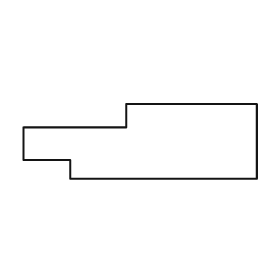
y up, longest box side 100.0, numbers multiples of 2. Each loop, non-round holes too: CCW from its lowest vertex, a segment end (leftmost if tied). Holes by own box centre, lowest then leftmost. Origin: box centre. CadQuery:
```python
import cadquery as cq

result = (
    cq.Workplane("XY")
    .moveTo(-30.0, -16.0)
    .lineTo(50.0, -16.0)
    .lineTo(50.0, 16.0)
    .lineTo(-6.0, 16.0)
    .lineTo(-6.0, 6.0)
    .lineTo(-50.0, 6.0)
    .lineTo(-50.0, -8.0)
    .lineTo(-30.0, -8.0)
    .close()
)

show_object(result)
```